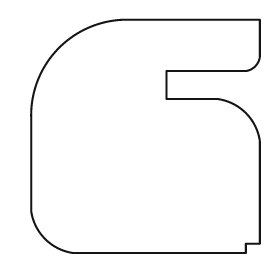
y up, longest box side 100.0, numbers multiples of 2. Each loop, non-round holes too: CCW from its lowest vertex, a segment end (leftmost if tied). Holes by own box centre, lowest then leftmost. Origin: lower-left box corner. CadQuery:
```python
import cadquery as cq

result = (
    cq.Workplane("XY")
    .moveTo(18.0, 0.0)
    .lineTo(92.0, 0.0)
    .lineTo(92.0, 4.0)
    .lineTo(98.0, 4.0)
    .lineTo(98.0, 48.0)
    .threePointArc((92.0, 60.0), (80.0, 66.0))
    .lineTo(58.0, 66.0)
    .lineTo(58.0, 78.0)
    .lineTo(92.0, 78.0)
    .threePointArc((96.0, 80.0), (98.0, 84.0))
    .lineTo(98.0, 100.0)
    .lineTo(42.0, 100.0)
    .threePointArc((12.0, 88.0), (0.0, 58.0))
    .lineTo(0.0, 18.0)
    .threePointArc((6.0, 6.0), (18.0, 0.0))
    .close()
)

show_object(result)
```